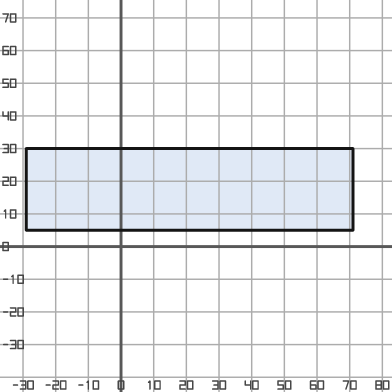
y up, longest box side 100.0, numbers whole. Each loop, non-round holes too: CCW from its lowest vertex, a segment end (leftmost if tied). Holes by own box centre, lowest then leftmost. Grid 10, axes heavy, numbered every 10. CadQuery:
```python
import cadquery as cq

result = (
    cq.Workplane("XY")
    .moveTo(-29.0, 5.0)
    .lineTo(71.0, 5.0)
    .lineTo(71.0, 30.0)
    .lineTo(-29.0, 30.0)
    .close()
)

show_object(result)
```